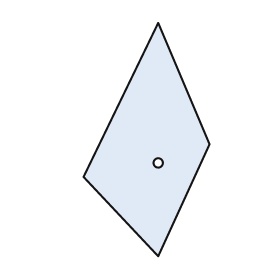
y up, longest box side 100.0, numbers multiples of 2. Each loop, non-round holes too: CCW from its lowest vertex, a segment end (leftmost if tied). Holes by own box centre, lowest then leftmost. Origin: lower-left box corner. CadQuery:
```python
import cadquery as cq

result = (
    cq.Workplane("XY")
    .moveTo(32.0, 0.0)
    .lineTo(54.0, 48.0)
    .lineTo(32.0, 100.0)
    .lineTo(0.0, 34.0)
    .close()
    .moveTo(32.0, 40.0)
    .circle(2.0)
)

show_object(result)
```